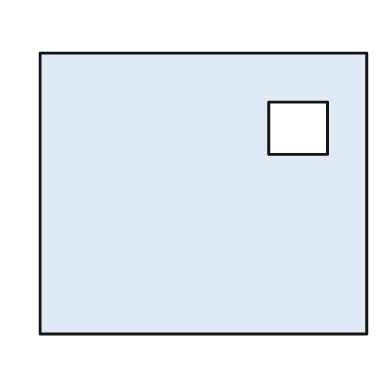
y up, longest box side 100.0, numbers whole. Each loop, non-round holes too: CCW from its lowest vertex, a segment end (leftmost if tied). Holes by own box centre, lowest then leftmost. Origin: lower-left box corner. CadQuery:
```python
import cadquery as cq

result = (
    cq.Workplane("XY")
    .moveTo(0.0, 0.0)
    .lineTo(100.0, 0.0)
    .lineTo(100.0, 86.0)
    .lineTo(0.0, 86.0)
    .close()
    .moveTo(70.0, 55.0)
    .lineTo(88.0, 55.0)
    .lineTo(88.0, 71.0)
    .lineTo(70.0, 71.0)
    .close()
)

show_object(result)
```